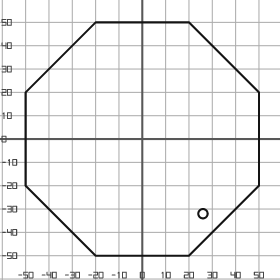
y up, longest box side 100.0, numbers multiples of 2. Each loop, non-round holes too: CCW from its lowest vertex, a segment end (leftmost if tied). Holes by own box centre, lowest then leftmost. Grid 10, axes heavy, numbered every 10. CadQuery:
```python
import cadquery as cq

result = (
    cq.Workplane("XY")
    .moveTo(-20.0, -50.0)
    .lineTo(20.0, -50.0)
    .lineTo(50.0, -20.0)
    .lineTo(50.0, 20.0)
    .lineTo(20.0, 50.0)
    .lineTo(-20.0, 50.0)
    .lineTo(-50.0, 20.0)
    .lineTo(-50.0, -20.0)
    .close()
    .moveTo(26.0, -32.0)
    .circle(2.0)
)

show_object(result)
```